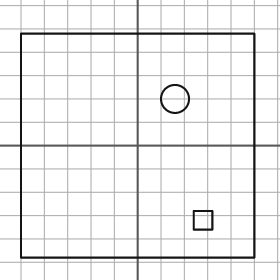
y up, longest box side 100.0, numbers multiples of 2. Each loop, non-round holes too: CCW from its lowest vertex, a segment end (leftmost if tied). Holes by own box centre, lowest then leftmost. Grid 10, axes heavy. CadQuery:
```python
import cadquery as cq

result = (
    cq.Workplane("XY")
    .moveTo(-50.0, -48.0)
    .lineTo(50.0, -48.0)
    .lineTo(50.0, 48.0)
    .lineTo(-50.0, 48.0)
    .close()
    .moveTo(24.0, -36.0)
    .lineTo(32.0, -36.0)
    .lineTo(32.0, -28.0)
    .lineTo(24.0, -28.0)
    .close()
    .moveTo(16.0, 20.0)
    .circle(6.0)
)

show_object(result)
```